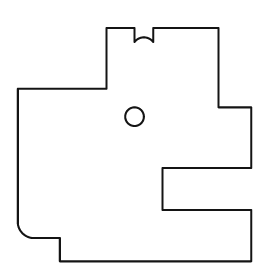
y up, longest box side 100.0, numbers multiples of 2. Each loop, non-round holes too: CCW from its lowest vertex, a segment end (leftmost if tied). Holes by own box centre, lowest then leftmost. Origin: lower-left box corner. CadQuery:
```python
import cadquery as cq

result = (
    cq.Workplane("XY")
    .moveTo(18.0, 0.0)
    .lineTo(100.0, 0.0)
    .lineTo(100.0, 22.0)
    .lineTo(62.0, 22.0)
    .lineTo(62.0, 40.0)
    .lineTo(100.0, 40.0)
    .lineTo(100.0, 66.0)
    .lineTo(86.0, 66.0)
    .lineTo(86.0, 100.0)
    .lineTo(58.0, 100.0)
    .lineTo(58.0, 94.0)
    .threePointArc((54.0, 96.0), (50.0, 94.0))
    .lineTo(50.0, 100.0)
    .lineTo(38.0, 100.0)
    .lineTo(38.0, 74.0)
    .lineTo(0.0, 74.0)
    .lineTo(0.0, 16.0)
    .threePointArc((2.0, 12.0), (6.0, 10.0))
    .lineTo(18.0, 10.0)
    .close()
    .moveTo(50.0, 62.0)
    .circle(4.0)
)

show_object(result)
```